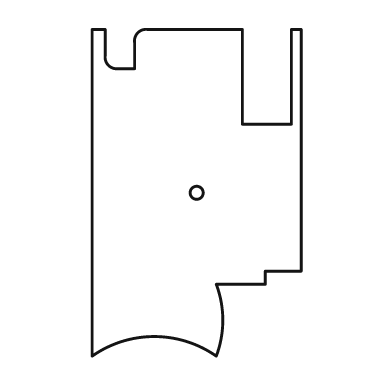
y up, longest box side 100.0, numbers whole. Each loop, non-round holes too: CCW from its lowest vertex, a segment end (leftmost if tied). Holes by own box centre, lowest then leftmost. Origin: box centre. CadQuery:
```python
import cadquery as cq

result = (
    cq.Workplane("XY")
    .moveTo(-32.0, -50.0)
    .threePointArc((-13.0, -44.0), (6.0, -50.0))
    .threePointArc((8.0, -39.0), (6.0, -28.0))
    .lineTo(21.0, -28.0)
    .lineTo(21.0, -24.0)
    .lineTo(32.0, -24.0)
    .lineTo(32.0, 50.0)
    .lineTo(29.0, 50.0)
    .lineTo(29.0, 21.0)
    .lineTo(14.0, 21.0)
    .lineTo(14.0, 50.0)
    .lineTo(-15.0, 50.0)
    .threePointArc((-18.0, 49.0), (-19.0, 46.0))
    .lineTo(-19.0, 38.0)
    .lineTo(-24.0, 38.0)
    .threePointArc((-27.0, 39.0), (-28.0, 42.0))
    .lineTo(-28.0, 50.0)
    .lineTo(-32.0, 50.0)
    .close()
    .moveTo(0.0, 0.0)
    .circle(2.0)
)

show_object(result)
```